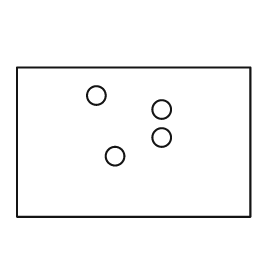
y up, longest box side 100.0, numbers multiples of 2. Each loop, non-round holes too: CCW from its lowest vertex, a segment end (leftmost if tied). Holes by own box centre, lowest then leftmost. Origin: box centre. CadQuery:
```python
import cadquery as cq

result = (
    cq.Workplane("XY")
    .moveTo(-50.0, -32.0)
    .lineTo(50.0, -32.0)
    .lineTo(50.0, 32.0)
    .lineTo(-50.0, 32.0)
    .close()
    .moveTo(-8.0, -6.0)
    .circle(4.0)
    .moveTo(12.0, 2.0)
    .circle(4.0)
    .moveTo(12.0, 14.0)
    .circle(4.0)
    .moveTo(-16.0, 20.0)
    .circle(4.0)
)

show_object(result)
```